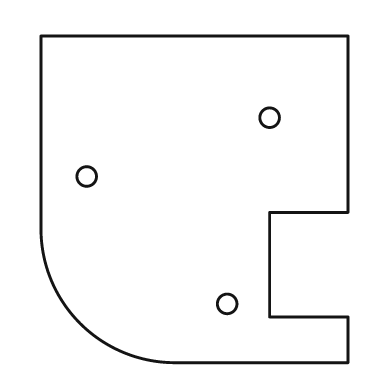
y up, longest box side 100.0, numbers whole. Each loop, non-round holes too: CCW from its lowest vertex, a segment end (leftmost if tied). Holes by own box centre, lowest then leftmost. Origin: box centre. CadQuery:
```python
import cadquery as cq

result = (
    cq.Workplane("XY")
    .moveTo(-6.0, -50.0)
    .lineTo(47.0, -50.0)
    .lineTo(47.0, -36.0)
    .lineTo(23.0, -36.0)
    .lineTo(23.0, -4.0)
    .lineTo(47.0, -4.0)
    .lineTo(47.0, 50.0)
    .lineTo(-47.0, 50.0)
    .lineTo(-47.0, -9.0)
    .threePointArc((-35.0, -38.0), (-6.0, -50.0))
    .close()
    .moveTo(10.0, -32.0)
    .circle(3.0)
    .moveTo(-33.0, 7.0)
    .circle(3.0)
    .moveTo(23.0, 25.0)
    .circle(3.0)
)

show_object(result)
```